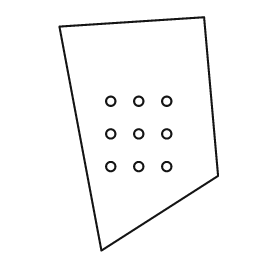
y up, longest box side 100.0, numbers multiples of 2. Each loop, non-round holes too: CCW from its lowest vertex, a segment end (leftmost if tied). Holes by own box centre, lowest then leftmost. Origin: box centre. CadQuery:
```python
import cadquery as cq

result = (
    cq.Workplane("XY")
    .moveTo(-16.0, -50.0)
    .lineTo(34.0, -18.0)
    .lineTo(28.0, 50.0)
    .lineTo(-34.0, 46.0)
    .close()
    .moveTo(-12.0, -14.0)
    .circle(2.0)
    .moveTo(0.0, -14.0)
    .circle(2.0)
    .moveTo(12.0, -14.0)
    .circle(2.0)
    .moveTo(-12.0, 0.0)
    .circle(2.0)
    .moveTo(0.0, 0.0)
    .circle(2.0)
    .moveTo(12.0, 0.0)
    .circle(2.0)
    .moveTo(-12.0, 14.0)
    .circle(2.0)
    .moveTo(0.0, 14.0)
    .circle(2.0)
    .moveTo(12.0, 14.0)
    .circle(2.0)
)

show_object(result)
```